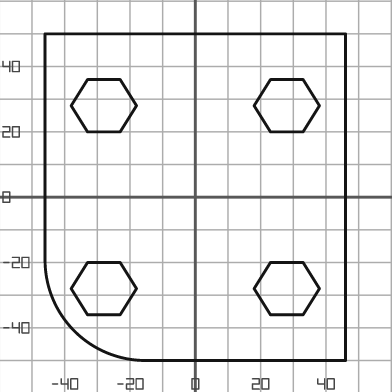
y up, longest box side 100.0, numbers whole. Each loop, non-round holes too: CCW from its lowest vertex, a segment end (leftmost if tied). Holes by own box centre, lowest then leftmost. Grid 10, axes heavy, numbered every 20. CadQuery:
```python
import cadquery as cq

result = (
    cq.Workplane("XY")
    .moveTo(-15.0, -50.0)
    .lineTo(46.0, -50.0)
    .lineTo(46.0, 50.0)
    .lineTo(-46.0, 50.0)
    .lineTo(-46.0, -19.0)
    .threePointArc((-37.0, -41.0), (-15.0, -50.0))
    .close()
    .moveTo(-33.0, -36.0)
    .lineTo(-23.0, -36.0)
    .lineTo(-18.0, -28.0)
    .lineTo(-23.0, -20.0)
    .lineTo(-33.0, -20.0)
    .lineTo(-38.0, -28.0)
    .close()
    .moveTo(23.0, -36.0)
    .lineTo(33.0, -36.0)
    .lineTo(38.0, -28.0)
    .lineTo(33.0, -20.0)
    .lineTo(23.0, -20.0)
    .lineTo(18.0, -28.0)
    .close()
    .moveTo(-33.0, 20.0)
    .lineTo(-23.0, 20.0)
    .lineTo(-18.0, 28.0)
    .lineTo(-23.0, 36.0)
    .lineTo(-33.0, 36.0)
    .lineTo(-38.0, 28.0)
    .close()
    .moveTo(23.0, 20.0)
    .lineTo(33.0, 20.0)
    .lineTo(38.0, 28.0)
    .lineTo(33.0, 36.0)
    .lineTo(23.0, 36.0)
    .lineTo(18.0, 28.0)
    .close()
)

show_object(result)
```